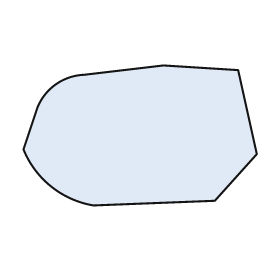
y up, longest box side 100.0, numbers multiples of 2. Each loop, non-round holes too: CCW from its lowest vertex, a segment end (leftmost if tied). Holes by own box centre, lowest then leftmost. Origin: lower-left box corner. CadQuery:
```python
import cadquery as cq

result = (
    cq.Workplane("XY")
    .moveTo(30.0, 0.0)
    .lineTo(82.0, 2.0)
    .lineTo(100.0, 22.0)
    .lineTo(92.0, 58.0)
    .lineTo(60.0, 60.0)
    .lineTo(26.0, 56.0)
    .threePointArc((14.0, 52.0), (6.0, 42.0))
    .lineTo(0.0, 24.0)
    .threePointArc((12.0, 8.0), (30.0, 0.0))
    .close()
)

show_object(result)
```